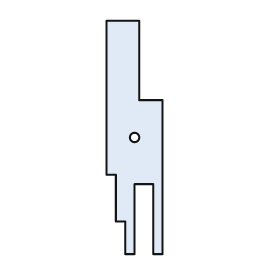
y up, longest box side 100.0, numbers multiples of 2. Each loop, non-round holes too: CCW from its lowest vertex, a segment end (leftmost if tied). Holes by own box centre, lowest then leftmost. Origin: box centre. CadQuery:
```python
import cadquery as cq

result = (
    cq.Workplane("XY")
    .moveTo(-4.0, -50.0)
    .lineTo(0.0, -50.0)
    .lineTo(0.0, -20.0)
    .lineTo(8.0, -20.0)
    .lineTo(8.0, -50.0)
    .lineTo(12.0, -50.0)
    .lineTo(12.0, 16.0)
    .lineTo(2.0, 16.0)
    .lineTo(2.0, 50.0)
    .lineTo(-12.0, 50.0)
    .lineTo(-12.0, -16.0)
    .lineTo(-8.0, -16.0)
    .lineTo(-8.0, -36.0)
    .lineTo(-4.0, -36.0)
    .close()
    .moveTo(0.0, 0.0)
    .circle(2.0)
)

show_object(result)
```